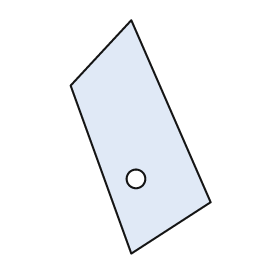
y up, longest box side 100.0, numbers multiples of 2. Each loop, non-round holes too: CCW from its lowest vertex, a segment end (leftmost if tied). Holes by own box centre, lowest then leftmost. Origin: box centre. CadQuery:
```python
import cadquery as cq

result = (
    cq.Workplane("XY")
    .moveTo(-4.0, -50.0)
    .lineTo(30.0, -28.0)
    .lineTo(-4.0, 50.0)
    .lineTo(-30.0, 22.0)
    .close()
    .moveTo(-2.0, -18.0)
    .circle(4.0)
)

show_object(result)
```